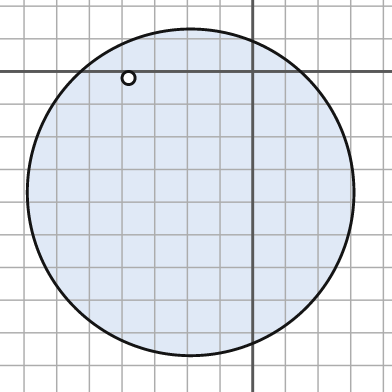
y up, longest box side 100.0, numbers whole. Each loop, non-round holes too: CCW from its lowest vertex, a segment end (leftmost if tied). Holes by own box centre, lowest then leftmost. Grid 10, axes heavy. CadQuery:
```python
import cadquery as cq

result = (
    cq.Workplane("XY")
    .moveTo(-19.0, -37.0)
    .circle(50.0)
    .moveTo(-38.0, -2.0)
    .circle(2.0)
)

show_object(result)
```